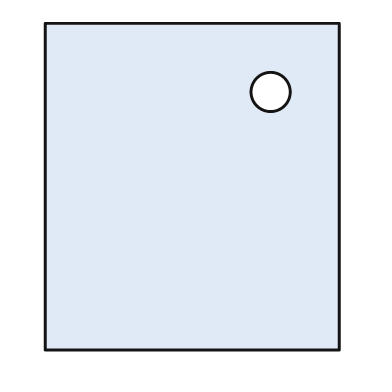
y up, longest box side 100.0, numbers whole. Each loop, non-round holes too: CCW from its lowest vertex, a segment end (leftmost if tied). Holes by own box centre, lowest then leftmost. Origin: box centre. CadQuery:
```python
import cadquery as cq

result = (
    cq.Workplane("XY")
    .moveTo(-45.0, -50.0)
    .lineTo(45.0, -50.0)
    .lineTo(45.0, 50.0)
    .lineTo(-45.0, 50.0)
    .close()
    .moveTo(24.0, 29.0)
    .circle(6.0)
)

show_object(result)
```